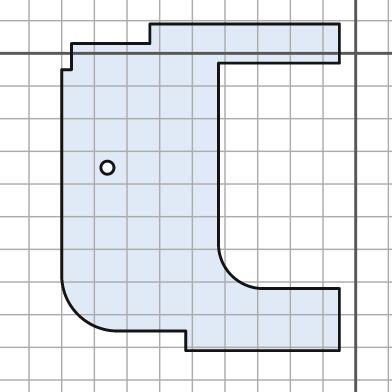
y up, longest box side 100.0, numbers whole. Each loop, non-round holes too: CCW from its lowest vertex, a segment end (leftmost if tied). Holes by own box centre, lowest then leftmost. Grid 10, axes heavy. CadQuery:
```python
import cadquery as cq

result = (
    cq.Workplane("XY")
    .moveTo(-52.0, -91.0)
    .lineTo(-5.0, -91.0)
    .lineTo(-5.0, -72.0)
    .lineTo(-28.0, -72.0)
    .threePointArc((-38.0, -68.0), (-42.0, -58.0))
    .lineTo(-42.0, -3.0)
    .lineTo(-5.0, -3.0)
    .lineTo(-5.0, 9.0)
    .lineTo(-63.0, 9.0)
    .lineTo(-63.0, 3.0)
    .lineTo(-87.0, 3.0)
    .lineTo(-87.0, -5.0)
    .lineTo(-90.0, -5.0)
    .lineTo(-90.0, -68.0)
    .threePointArc((-85.0, -80.0), (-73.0, -85.0))
    .lineTo(-52.0, -85.0)
    .close()
    .moveTo(-76.0, -35.0)
    .circle(2.0)
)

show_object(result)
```